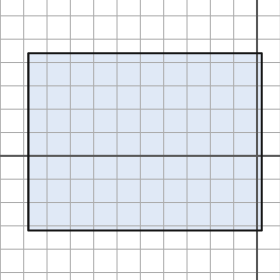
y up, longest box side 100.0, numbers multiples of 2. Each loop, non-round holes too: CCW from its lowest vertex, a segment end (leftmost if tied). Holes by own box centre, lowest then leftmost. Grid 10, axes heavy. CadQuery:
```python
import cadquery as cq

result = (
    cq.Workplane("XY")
    .moveTo(-98.0, -32.0)
    .lineTo(2.0, -32.0)
    .lineTo(2.0, 44.0)
    .lineTo(-98.0, 44.0)
    .close()
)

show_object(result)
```